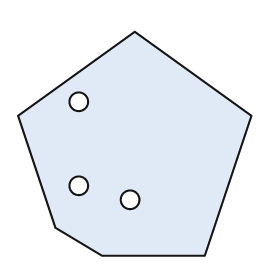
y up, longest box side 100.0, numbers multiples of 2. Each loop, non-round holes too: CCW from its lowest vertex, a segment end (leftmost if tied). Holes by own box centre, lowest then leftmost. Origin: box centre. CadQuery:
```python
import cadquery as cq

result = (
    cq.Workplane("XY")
    .moveTo(-14.0, -48.0)
    .lineTo(30.0, -48.0)
    .lineTo(50.0, 12.0)
    .lineTo(0.0, 48.0)
    .lineTo(-50.0, 12.0)
    .lineTo(-34.0, -36.0)
    .close()
    .moveTo(-2.0, -24.0)
    .circle(4.0)
    .moveTo(-24.0, -18.0)
    .circle(4.0)
    .moveTo(-24.0, 18.0)
    .circle(4.0)
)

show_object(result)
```